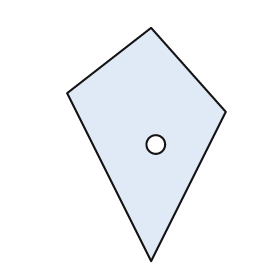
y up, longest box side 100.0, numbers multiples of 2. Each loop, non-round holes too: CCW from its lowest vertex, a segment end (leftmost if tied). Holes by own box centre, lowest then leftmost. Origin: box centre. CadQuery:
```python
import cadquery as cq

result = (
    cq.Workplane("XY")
    .moveTo(2.0, -50.0)
    .lineTo(34.0, 14.0)
    .lineTo(2.0, 50.0)
    .lineTo(-34.0, 22.0)
    .close()
    .moveTo(4.0, 0.0)
    .circle(4.0)
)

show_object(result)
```